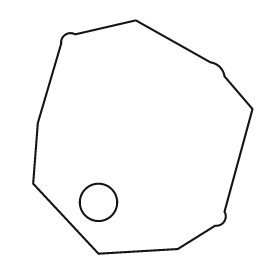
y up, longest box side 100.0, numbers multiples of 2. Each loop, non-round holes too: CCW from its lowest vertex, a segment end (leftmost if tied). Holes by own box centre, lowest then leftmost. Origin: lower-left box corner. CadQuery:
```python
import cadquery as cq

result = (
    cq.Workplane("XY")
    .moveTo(28.0, 0.0)
    .lineTo(62.0, 2.0)
    .lineTo(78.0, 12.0)
    .threePointArc((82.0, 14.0), (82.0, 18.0))
    .lineTo(94.0, 62.0)
    .lineTo(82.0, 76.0)
    .threePointArc((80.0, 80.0), (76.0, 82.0))
    .lineTo(44.0, 100.0)
    .lineTo(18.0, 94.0)
    .threePointArc((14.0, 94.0), (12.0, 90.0))
    .lineTo(2.0, 56.0)
    .lineTo(0.0, 30.0)
    .close()
    .moveTo(28.0, 22.0)
    .circle(8.0)
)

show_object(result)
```